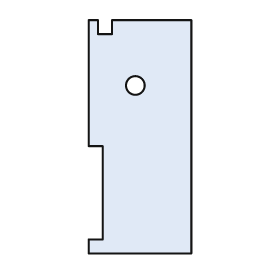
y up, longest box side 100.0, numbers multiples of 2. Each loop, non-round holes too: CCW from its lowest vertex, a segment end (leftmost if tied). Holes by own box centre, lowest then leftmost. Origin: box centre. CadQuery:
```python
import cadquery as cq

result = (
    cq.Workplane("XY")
    .moveTo(-22.0, -50.0)
    .lineTo(22.0, -50.0)
    .lineTo(22.0, 50.0)
    .lineTo(-12.0, 50.0)
    .lineTo(-12.0, 44.0)
    .lineTo(-18.0, 44.0)
    .lineTo(-18.0, 50.0)
    .lineTo(-22.0, 50.0)
    .lineTo(-22.0, -4.0)
    .lineTo(-16.0, -4.0)
    .lineTo(-16.0, -44.0)
    .lineTo(-22.0, -44.0)
    .close()
    .moveTo(-2.0, 22.0)
    .circle(4.0)
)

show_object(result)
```